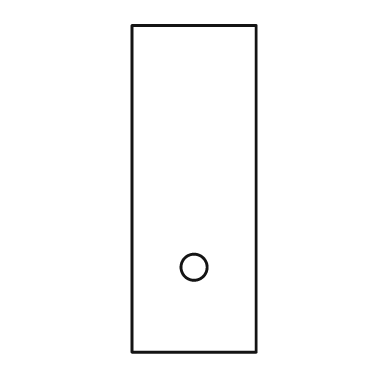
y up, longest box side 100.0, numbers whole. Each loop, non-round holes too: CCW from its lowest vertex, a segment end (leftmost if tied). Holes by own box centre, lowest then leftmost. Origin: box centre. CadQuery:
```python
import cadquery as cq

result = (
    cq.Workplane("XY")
    .moveTo(-19.0, -50.0)
    .lineTo(19.0, -50.0)
    .lineTo(19.0, 50.0)
    .lineTo(-19.0, 50.0)
    .close()
    .moveTo(0.0, -24.0)
    .circle(4.0)
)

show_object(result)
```